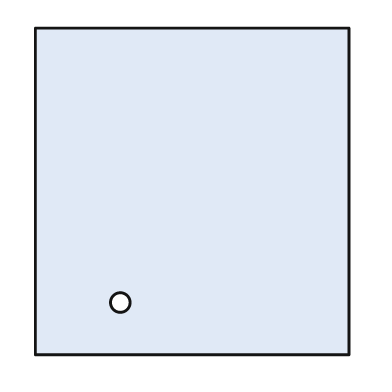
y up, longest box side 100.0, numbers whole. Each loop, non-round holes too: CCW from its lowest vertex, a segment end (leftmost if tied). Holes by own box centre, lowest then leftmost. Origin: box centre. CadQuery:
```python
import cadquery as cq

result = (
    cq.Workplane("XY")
    .moveTo(-48.0, -50.0)
    .lineTo(48.0, -50.0)
    .lineTo(48.0, 50.0)
    .lineTo(-48.0, 50.0)
    .close()
    .moveTo(-22.0, -34.0)
    .circle(3.0)
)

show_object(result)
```